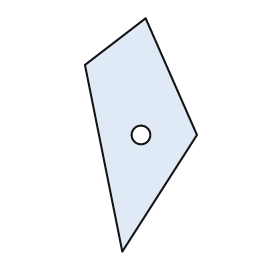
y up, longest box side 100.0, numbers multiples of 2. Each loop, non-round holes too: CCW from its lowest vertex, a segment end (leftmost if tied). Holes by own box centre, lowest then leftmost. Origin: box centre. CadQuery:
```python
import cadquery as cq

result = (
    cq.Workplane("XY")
    .moveTo(-8.0, -50.0)
    .lineTo(24.0, 0.0)
    .lineTo(2.0, 50.0)
    .lineTo(-24.0, 30.0)
    .close()
    .moveTo(0.0, 0.0)
    .circle(4.0)
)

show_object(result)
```